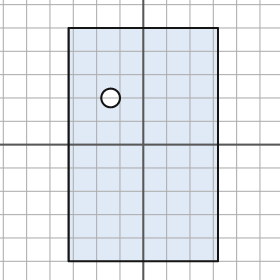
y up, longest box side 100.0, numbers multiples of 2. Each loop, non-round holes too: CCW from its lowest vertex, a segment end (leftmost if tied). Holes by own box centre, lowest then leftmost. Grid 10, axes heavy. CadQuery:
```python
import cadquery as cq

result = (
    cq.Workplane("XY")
    .moveTo(-32.0, -50.0)
    .lineTo(32.0, -50.0)
    .lineTo(32.0, 50.0)
    .lineTo(-32.0, 50.0)
    .close()
    .moveTo(-14.0, 20.0)
    .circle(4.0)
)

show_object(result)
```